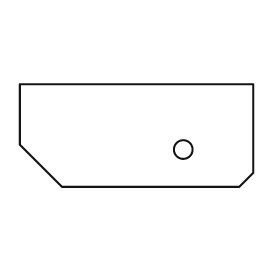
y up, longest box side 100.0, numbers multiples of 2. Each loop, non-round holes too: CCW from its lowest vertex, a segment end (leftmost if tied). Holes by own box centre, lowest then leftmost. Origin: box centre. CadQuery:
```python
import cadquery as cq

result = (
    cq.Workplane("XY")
    .moveTo(-32.0, -22.0)
    .lineTo(44.0, -22.0)
    .lineTo(50.0, -16.0)
    .lineTo(50.0, 22.0)
    .lineTo(-50.0, 22.0)
    .lineTo(-50.0, -4.0)
    .close()
    .moveTo(20.0, -6.0)
    .circle(4.0)
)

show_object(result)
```